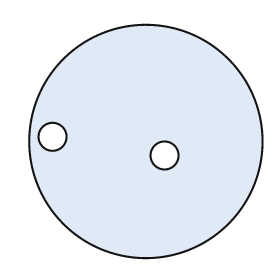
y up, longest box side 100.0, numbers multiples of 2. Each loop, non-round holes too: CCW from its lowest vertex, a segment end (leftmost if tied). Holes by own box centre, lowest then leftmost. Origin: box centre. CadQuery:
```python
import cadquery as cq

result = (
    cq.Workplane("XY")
    .moveTo(0.0, 0.0)
    .circle(50.0)
    .moveTo(8.0, -6.0)
    .circle(6.0)
    .moveTo(-40.0, 2.0)
    .circle(6.0)
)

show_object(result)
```